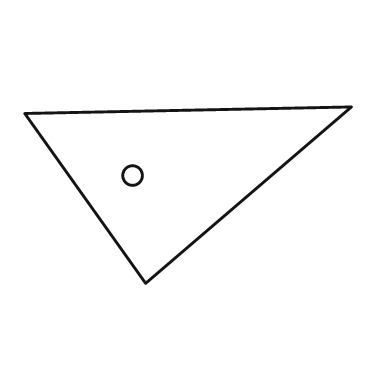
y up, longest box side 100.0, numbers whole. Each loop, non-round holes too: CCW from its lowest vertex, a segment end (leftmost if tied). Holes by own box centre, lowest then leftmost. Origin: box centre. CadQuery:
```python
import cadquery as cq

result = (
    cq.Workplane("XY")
    .moveTo(-13.0, -27.0)
    .lineTo(50.0, 27.0)
    .lineTo(-50.0, 25.0)
    .close()
    .moveTo(-17.0, 6.0)
    .circle(3.0)
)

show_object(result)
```